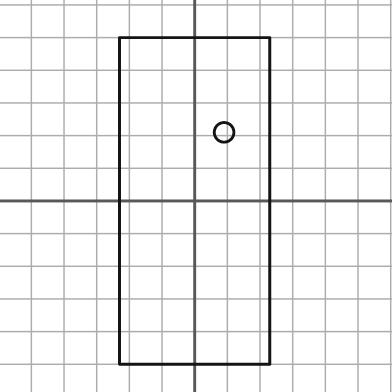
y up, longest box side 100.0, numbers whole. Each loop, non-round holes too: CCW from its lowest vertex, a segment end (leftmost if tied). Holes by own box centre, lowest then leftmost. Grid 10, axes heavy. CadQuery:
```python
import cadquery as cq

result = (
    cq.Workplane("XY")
    .moveTo(-23.0, -50.0)
    .lineTo(23.0, -50.0)
    .lineTo(23.0, 50.0)
    .lineTo(-23.0, 50.0)
    .close()
    .moveTo(9.0, 21.0)
    .circle(3.0)
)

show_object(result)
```